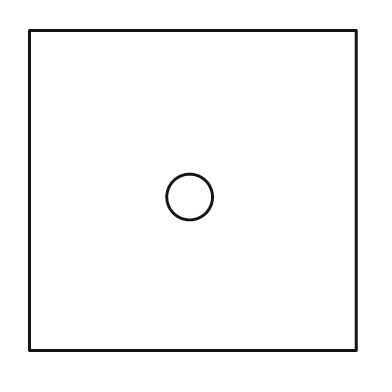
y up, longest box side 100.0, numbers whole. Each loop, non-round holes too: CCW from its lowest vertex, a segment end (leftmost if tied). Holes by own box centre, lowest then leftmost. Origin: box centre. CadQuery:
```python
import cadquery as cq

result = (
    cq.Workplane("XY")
    .moveTo(-50.0, -49.0)
    .lineTo(50.0, -49.0)
    .lineTo(50.0, 49.0)
    .lineTo(-50.0, 49.0)
    .close()
    .moveTo(-1.0, -2.0)
    .circle(7.0)
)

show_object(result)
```